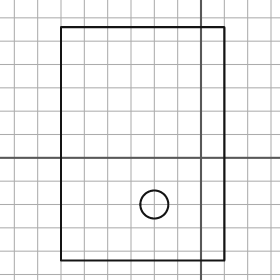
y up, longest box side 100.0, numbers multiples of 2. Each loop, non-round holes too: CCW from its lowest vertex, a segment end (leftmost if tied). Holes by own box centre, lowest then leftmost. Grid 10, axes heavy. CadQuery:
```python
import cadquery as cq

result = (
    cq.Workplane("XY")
    .moveTo(-60.0, -44.0)
    .lineTo(10.0, -44.0)
    .lineTo(10.0, 56.0)
    .lineTo(-60.0, 56.0)
    .close()
    .moveTo(-20.0, -20.0)
    .circle(6.0)
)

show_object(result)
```